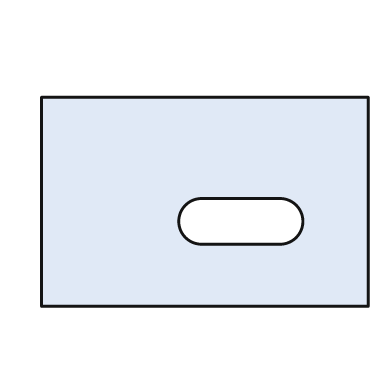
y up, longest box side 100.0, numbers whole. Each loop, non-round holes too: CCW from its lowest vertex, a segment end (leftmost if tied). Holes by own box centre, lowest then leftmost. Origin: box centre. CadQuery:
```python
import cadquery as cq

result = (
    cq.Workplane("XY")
    .moveTo(-50.0, -32.0)
    .lineTo(50.0, -32.0)
    .lineTo(50.0, 32.0)
    .lineTo(-50.0, 32.0)
    .close()
    .moveTo(-1.0, -13.0)
    .lineTo(23.0, -13.0)
    .threePointArc((30.0, -6.0), (23.0, 1.0))
    .lineTo(-1.0, 1.0)
    .threePointArc((-8.0, -6.0), (-1.0, -13.0))
    .close()
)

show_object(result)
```